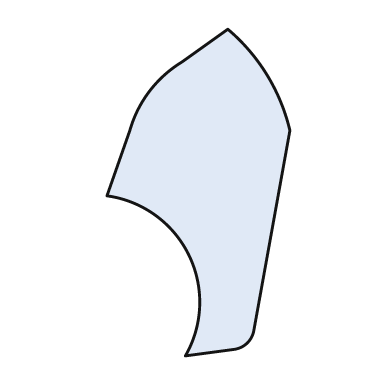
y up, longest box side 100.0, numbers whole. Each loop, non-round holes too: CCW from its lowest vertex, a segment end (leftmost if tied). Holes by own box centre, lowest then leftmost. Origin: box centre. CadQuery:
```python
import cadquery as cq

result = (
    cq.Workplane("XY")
    .moveTo(-4.0, -50.0)
    .lineTo(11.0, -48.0)
    .threePointArc((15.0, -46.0), (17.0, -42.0))
    .lineTo(28.0, 19.0)
    .threePointArc((21.0, 36.0), (9.0, 50.0))
    .lineTo(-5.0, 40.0)
    .threePointArc((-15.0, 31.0), (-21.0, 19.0))
    .lineTo(-28.0, -1.0)
    .threePointArc((-3.0, -19.0), (-4.0, -50.0))
    .close()
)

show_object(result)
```